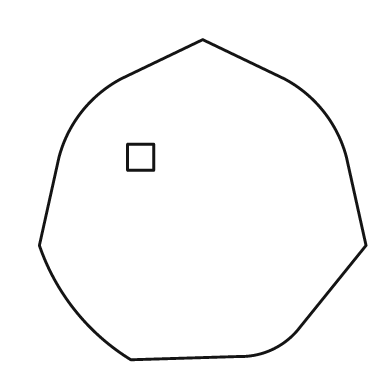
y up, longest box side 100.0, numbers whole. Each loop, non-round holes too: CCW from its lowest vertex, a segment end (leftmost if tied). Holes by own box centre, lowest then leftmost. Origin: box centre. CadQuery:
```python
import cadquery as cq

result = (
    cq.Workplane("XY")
    .moveTo(-22.0, -49.0)
    .lineTo(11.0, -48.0)
    .threePointArc((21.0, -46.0), (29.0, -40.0))
    .lineTo(50.0, -14.0)
    .lineTo(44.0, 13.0)
    .threePointArc((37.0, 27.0), (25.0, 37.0))
    .lineTo(0.0, 49.0)
    .lineTo(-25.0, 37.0)
    .threePointArc((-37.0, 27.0), (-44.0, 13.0))
    .lineTo(-50.0, -14.0)
    .threePointArc((-39.0, -34.0), (-22.0, -49.0))
    .close()
    .moveTo(-23.0, 9.0)
    .lineTo(-15.0, 9.0)
    .lineTo(-15.0, 17.0)
    .lineTo(-23.0, 17.0)
    .close()
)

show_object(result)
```